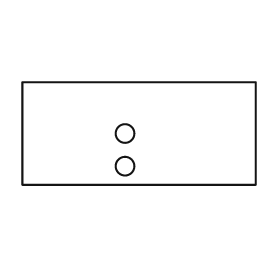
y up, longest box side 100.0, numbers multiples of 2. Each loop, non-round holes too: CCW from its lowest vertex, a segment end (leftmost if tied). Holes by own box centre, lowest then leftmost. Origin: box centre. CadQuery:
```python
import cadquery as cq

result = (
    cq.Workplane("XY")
    .moveTo(-50.0, -22.0)
    .lineTo(50.0, -22.0)
    .lineTo(50.0, 22.0)
    .lineTo(-50.0, 22.0)
    .close()
    .moveTo(-6.0, -14.0)
    .circle(4.0)
    .moveTo(-6.0, 0.0)
    .circle(4.0)
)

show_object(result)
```